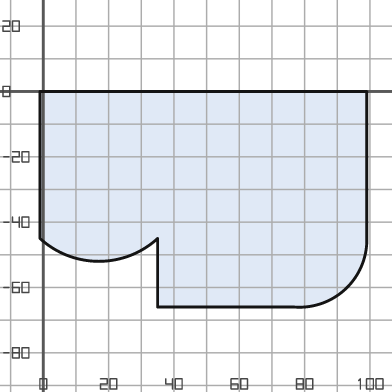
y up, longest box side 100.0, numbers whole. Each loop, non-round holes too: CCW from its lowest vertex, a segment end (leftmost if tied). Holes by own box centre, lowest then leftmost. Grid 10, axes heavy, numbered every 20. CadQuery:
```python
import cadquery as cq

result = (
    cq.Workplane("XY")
    .moveTo(35.0, -66.0)
    .lineTo(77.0, -66.0)
    .threePointArc((93.0, -60.0), (99.0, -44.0))
    .lineTo(99.0, 0.0)
    .lineTo(-1.0, 0.0)
    .lineTo(-1.0, -45.0)
    .threePointArc((17.0, -52.0), (35.0, -45.0))
    .close()
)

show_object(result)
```